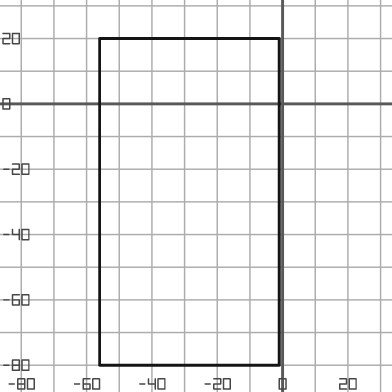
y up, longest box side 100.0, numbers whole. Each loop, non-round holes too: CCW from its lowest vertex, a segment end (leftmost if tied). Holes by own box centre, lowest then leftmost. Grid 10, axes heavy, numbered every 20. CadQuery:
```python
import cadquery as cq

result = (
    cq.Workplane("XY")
    .moveTo(-56.0, -80.0)
    .lineTo(-1.0, -80.0)
    .lineTo(-1.0, 20.0)
    .lineTo(-56.0, 20.0)
    .close()
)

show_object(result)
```